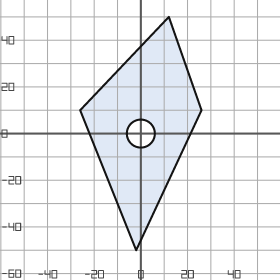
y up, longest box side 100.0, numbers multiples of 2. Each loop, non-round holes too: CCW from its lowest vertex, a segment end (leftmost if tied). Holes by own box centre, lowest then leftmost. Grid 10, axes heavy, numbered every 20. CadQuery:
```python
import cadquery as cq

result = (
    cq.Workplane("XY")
    .moveTo(-2.0, -50.0)
    .lineTo(26.0, 10.0)
    .lineTo(12.0, 50.0)
    .lineTo(-26.0, 10.0)
    .close()
    .moveTo(0.0, 0.0)
    .circle(6.0)
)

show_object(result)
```